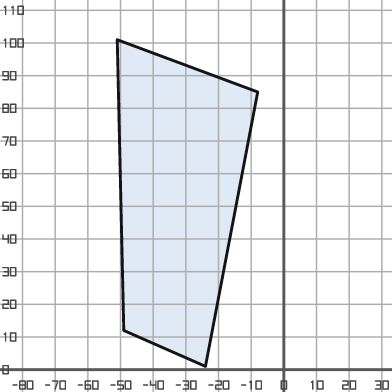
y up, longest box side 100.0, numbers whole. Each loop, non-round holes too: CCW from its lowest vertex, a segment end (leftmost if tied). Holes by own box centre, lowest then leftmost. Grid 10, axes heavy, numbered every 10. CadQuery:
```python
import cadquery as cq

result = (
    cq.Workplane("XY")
    .moveTo(-24.0, 1.0)
    .lineTo(-8.0, 85.0)
    .lineTo(-51.0, 101.0)
    .lineTo(-49.0, 12.0)
    .close()
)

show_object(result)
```